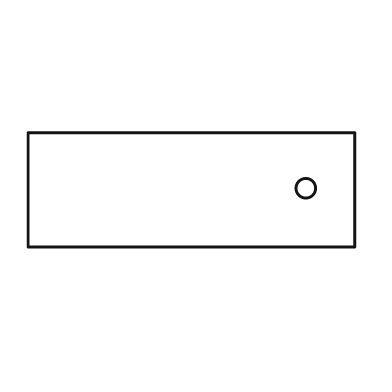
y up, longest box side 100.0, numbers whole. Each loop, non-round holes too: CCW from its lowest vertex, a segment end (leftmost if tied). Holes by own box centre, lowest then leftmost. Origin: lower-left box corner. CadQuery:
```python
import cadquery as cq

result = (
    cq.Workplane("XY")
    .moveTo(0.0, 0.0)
    .lineTo(100.0, 0.0)
    .lineTo(100.0, 35.0)
    .lineTo(0.0, 35.0)
    .close()
    .moveTo(85.0, 18.0)
    .circle(3.0)
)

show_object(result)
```